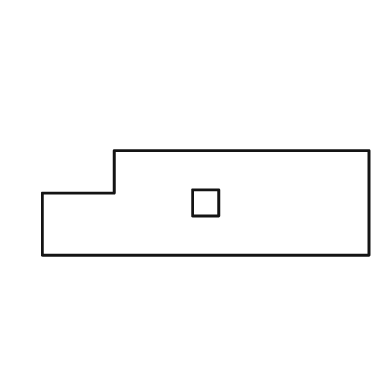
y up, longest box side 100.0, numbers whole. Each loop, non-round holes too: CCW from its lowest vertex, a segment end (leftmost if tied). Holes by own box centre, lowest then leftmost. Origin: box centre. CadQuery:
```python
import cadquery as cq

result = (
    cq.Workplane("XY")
    .moveTo(-50.0, -16.0)
    .lineTo(50.0, -16.0)
    .lineTo(50.0, 16.0)
    .lineTo(-28.0, 16.0)
    .lineTo(-28.0, 3.0)
    .lineTo(-50.0, 3.0)
    .close()
    .moveTo(-4.0, -4.0)
    .lineTo(4.0, -4.0)
    .lineTo(4.0, 4.0)
    .lineTo(-4.0, 4.0)
    .close()
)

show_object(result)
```